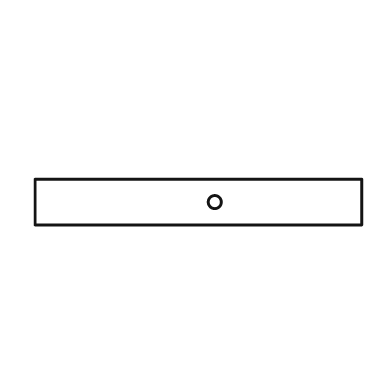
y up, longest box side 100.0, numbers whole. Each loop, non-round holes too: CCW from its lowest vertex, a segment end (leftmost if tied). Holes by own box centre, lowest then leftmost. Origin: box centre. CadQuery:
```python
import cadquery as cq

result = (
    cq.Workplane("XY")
    .moveTo(-50.0, -7.0)
    .lineTo(50.0, -7.0)
    .lineTo(50.0, 7.0)
    .lineTo(-50.0, 7.0)
    .close()
    .moveTo(5.0, 0.0)
    .circle(2.0)
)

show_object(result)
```